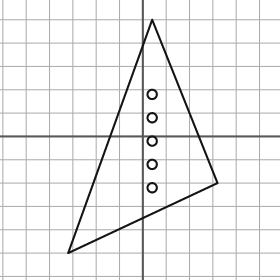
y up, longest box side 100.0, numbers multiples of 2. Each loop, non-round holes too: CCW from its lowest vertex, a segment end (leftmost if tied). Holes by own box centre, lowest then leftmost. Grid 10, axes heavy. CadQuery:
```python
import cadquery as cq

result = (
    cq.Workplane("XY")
    .moveTo(-32.0, -50.0)
    .lineTo(32.0, -20.0)
    .lineTo(4.0, 50.0)
    .close()
    .moveTo(4.0, -22.0)
    .circle(2.0)
    .moveTo(4.0, -12.0)
    .circle(2.0)
    .moveTo(4.0, -2.0)
    .circle(2.0)
    .moveTo(4.0, 8.0)
    .circle(2.0)
    .moveTo(4.0, 18.0)
    .circle(2.0)
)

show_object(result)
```